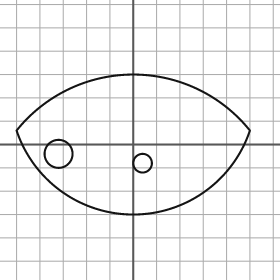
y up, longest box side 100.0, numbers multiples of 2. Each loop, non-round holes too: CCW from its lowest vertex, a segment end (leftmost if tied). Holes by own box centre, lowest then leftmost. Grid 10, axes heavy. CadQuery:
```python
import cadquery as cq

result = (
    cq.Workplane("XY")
    .moveTo(-50.0, 6.0)
    .threePointArc((0.0, -30.0), (50.0, 6.0))
    .threePointArc((0.0, 30.0), (-50.0, 6.0))
    .close()
    .moveTo(4.0, -8.0)
    .circle(4.0)
    .moveTo(-32.0, -4.0)
    .circle(6.0)
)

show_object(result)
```